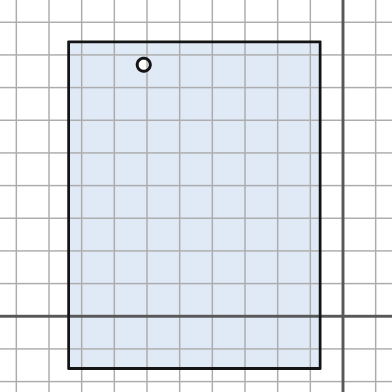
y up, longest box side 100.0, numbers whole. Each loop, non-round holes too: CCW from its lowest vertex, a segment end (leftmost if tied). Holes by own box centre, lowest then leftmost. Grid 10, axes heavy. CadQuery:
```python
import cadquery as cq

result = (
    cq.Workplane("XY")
    .moveTo(-84.0, -16.0)
    .lineTo(-7.0, -16.0)
    .lineTo(-7.0, 84.0)
    .lineTo(-84.0, 84.0)
    .close()
    .moveTo(-61.0, 77.0)
    .circle(2.0)
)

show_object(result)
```